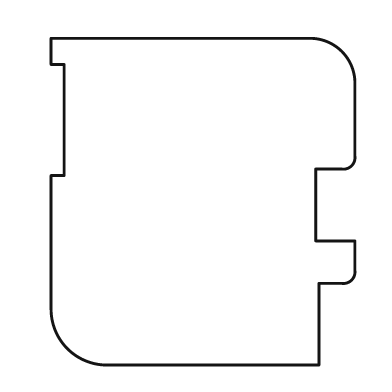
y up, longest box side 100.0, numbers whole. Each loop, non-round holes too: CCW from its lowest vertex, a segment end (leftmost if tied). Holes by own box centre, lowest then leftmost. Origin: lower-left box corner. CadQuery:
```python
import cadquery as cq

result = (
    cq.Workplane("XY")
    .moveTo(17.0, 0.0)
    .lineTo(82.0, 0.0)
    .lineTo(82.0, 25.0)
    .lineTo(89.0, 25.0)
    .threePointArc((92.0, 26.0), (93.0, 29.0))
    .lineTo(93.0, 38.0)
    .lineTo(81.0, 38.0)
    .lineTo(81.0, 60.0)
    .lineTo(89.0, 60.0)
    .threePointArc((92.0, 61.0), (93.0, 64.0))
    .lineTo(93.0, 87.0)
    .threePointArc((89.0, 96.0), (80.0, 100.0))
    .lineTo(0.0, 100.0)
    .lineTo(0.0, 92.0)
    .lineTo(4.0, 92.0)
    .lineTo(4.0, 58.0)
    .lineTo(0.0, 58.0)
    .lineTo(0.0, 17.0)
    .threePointArc((5.0, 5.0), (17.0, 0.0))
    .close()
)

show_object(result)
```